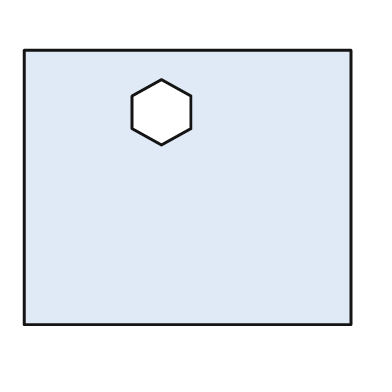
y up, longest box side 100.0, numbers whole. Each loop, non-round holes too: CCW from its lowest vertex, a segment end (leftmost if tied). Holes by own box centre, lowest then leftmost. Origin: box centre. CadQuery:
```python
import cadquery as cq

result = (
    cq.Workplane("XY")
    .moveTo(-50.0, -42.0)
    .lineTo(50.0, -42.0)
    .lineTo(50.0, 42.0)
    .lineTo(-50.0, 42.0)
    .close()
    .moveTo(-8.0, 13.0)
    .lineTo(1.0, 18.0)
    .lineTo(1.0, 28.0)
    .lineTo(-8.0, 33.0)
    .lineTo(-17.0, 28.0)
    .lineTo(-17.0, 18.0)
    .close()
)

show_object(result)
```